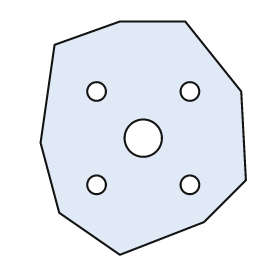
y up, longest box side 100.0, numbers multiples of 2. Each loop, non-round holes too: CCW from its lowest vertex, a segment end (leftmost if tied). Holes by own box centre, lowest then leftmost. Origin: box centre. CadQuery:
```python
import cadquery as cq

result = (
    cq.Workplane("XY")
    .moveTo(-10.0, -50.0)
    .lineTo(26.0, -36.0)
    .lineTo(44.0, -18.0)
    .lineTo(42.0, 20.0)
    .lineTo(18.0, 50.0)
    .lineTo(-10.0, 50.0)
    .lineTo(-38.0, 40.0)
    .lineTo(-44.0, -2.0)
    .lineTo(-36.0, -32.0)
    .close()
    .moveTo(-20.0, -20.0)
    .circle(4.0)
    .moveTo(20.0, -20.0)
    .circle(4.0)
    .moveTo(0.0, 0.0)
    .circle(8.0)
    .moveTo(-20.0, 20.0)
    .circle(4.0)
    .moveTo(20.0, 20.0)
    .circle(4.0)
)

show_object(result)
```